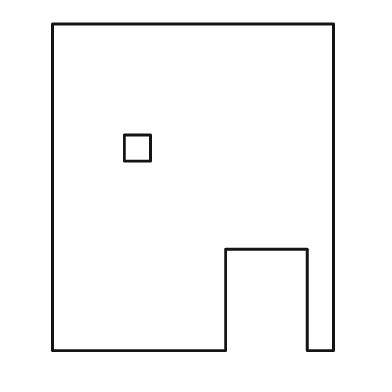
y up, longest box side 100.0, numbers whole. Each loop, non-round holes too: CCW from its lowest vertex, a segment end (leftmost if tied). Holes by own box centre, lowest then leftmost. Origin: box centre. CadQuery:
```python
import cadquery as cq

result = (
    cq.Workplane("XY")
    .moveTo(-43.0, -50.0)
    .lineTo(10.0, -50.0)
    .lineTo(10.0, -19.0)
    .lineTo(35.0, -19.0)
    .lineTo(35.0, -50.0)
    .lineTo(43.0, -50.0)
    .lineTo(43.0, 50.0)
    .lineTo(-43.0, 50.0)
    .close()
    .moveTo(-21.0, 8.0)
    .lineTo(-13.0, 8.0)
    .lineTo(-13.0, 16.0)
    .lineTo(-21.0, 16.0)
    .close()
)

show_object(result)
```